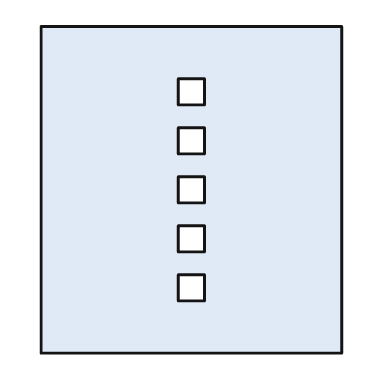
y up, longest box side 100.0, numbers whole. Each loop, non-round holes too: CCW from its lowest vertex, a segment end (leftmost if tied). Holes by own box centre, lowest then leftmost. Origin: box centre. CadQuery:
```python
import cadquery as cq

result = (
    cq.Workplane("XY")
    .moveTo(-46.0, -50.0)
    .lineTo(46.0, -50.0)
    .lineTo(46.0, 50.0)
    .lineTo(-46.0, 50.0)
    .close()
    .moveTo(-4.0, -34.0)
    .lineTo(4.0, -34.0)
    .lineTo(4.0, -26.0)
    .lineTo(-4.0, -26.0)
    .close()
    .moveTo(-4.0, -19.0)
    .lineTo(4.0, -19.0)
    .lineTo(4.0, -11.0)
    .lineTo(-4.0, -11.0)
    .close()
    .moveTo(-4.0, -4.0)
    .lineTo(4.0, -4.0)
    .lineTo(4.0, 4.0)
    .lineTo(-4.0, 4.0)
    .close()
    .moveTo(-4.0, 11.0)
    .lineTo(4.0, 11.0)
    .lineTo(4.0, 19.0)
    .lineTo(-4.0, 19.0)
    .close()
    .moveTo(-4.0, 26.0)
    .lineTo(4.0, 26.0)
    .lineTo(4.0, 34.0)
    .lineTo(-4.0, 34.0)
    .close()
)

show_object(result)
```